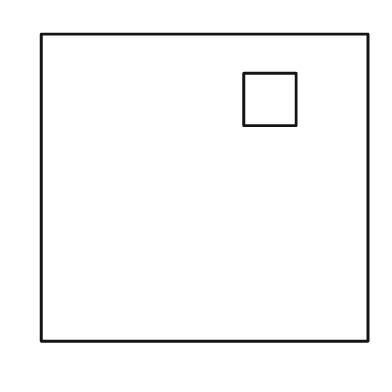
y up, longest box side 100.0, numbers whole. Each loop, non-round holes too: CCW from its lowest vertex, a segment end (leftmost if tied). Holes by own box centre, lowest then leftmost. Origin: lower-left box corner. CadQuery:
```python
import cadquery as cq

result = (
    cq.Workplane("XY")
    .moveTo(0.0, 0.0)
    .lineTo(100.0, 0.0)
    .lineTo(100.0, 94.0)
    .lineTo(0.0, 94.0)
    .close()
    .moveTo(62.0, 66.0)
    .lineTo(78.0, 66.0)
    .lineTo(78.0, 82.0)
    .lineTo(62.0, 82.0)
    .close()
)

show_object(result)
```